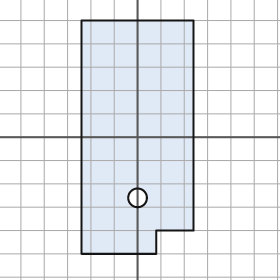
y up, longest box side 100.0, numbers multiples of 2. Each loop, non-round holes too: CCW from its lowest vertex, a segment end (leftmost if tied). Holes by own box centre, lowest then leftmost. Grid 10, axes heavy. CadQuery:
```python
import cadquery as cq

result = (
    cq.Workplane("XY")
    .moveTo(-24.0, -50.0)
    .lineTo(8.0, -50.0)
    .lineTo(8.0, -40.0)
    .lineTo(24.0, -40.0)
    .lineTo(24.0, 50.0)
    .lineTo(-24.0, 50.0)
    .close()
    .moveTo(0.0, -26.0)
    .circle(4.0)
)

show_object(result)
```